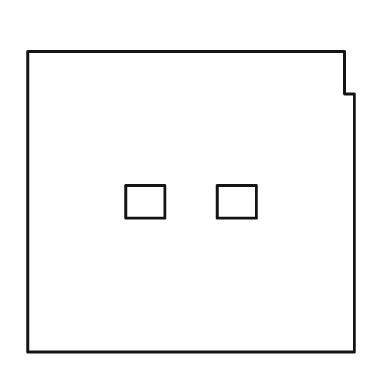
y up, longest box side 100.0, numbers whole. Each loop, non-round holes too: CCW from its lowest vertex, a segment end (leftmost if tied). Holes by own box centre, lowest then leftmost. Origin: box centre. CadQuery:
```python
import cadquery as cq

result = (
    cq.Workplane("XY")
    .moveTo(-50.0, -46.0)
    .lineTo(50.0, -46.0)
    .lineTo(50.0, 33.0)
    .lineTo(47.0, 33.0)
    .lineTo(47.0, 46.0)
    .lineTo(-50.0, 46.0)
    .close()
    .moveTo(-20.0, -5.0)
    .lineTo(-8.0, -5.0)
    .lineTo(-8.0, 5.0)
    .lineTo(-20.0, 5.0)
    .close()
    .moveTo(8.0, -5.0)
    .lineTo(20.0, -5.0)
    .lineTo(20.0, 5.0)
    .lineTo(8.0, 5.0)
    .close()
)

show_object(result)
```